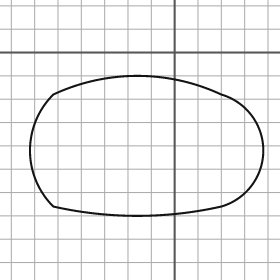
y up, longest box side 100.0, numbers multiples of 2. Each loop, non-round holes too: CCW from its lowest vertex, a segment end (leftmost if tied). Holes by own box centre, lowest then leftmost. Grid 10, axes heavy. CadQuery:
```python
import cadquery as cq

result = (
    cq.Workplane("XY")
    .moveTo(-52.0, -66.0)
    .threePointArc((-16.0, -70.0), (20.0, -66.0))
    .threePointArc((38.0, -42.0), (20.0, -18.0))
    .threePointArc((-16.0, -10.0), (-52.0, -18.0))
    .threePointArc((-62.0, -42.0), (-52.0, -66.0))
    .close()
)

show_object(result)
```